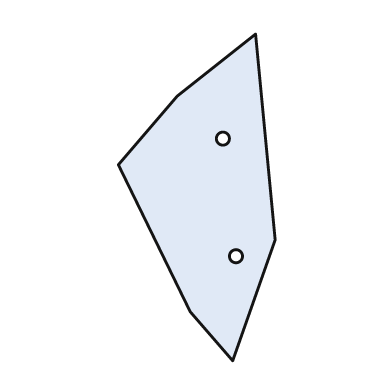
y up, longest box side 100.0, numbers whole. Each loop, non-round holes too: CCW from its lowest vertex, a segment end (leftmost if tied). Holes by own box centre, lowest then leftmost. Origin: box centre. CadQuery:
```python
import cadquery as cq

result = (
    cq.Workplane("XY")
    .moveTo(11.0, -50.0)
    .lineTo(24.0, -13.0)
    .lineTo(18.0, 50.0)
    .lineTo(-6.0, 31.0)
    .lineTo(-24.0, 10.0)
    .lineTo(-2.0, -35.0)
    .close()
    .moveTo(12.0, -18.0)
    .circle(2.0)
    .moveTo(8.0, 18.0)
    .circle(2.0)
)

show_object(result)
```